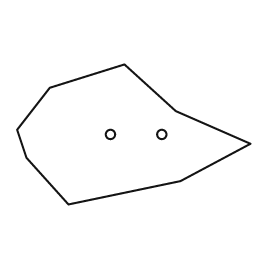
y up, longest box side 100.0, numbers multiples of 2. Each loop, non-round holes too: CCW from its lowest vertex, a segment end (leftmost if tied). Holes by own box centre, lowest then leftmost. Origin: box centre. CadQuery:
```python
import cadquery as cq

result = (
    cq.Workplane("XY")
    .moveTo(-28.0, -30.0)
    .lineTo(20.0, -20.0)
    .lineTo(50.0, -4.0)
    .lineTo(18.0, 10.0)
    .lineTo(-4.0, 30.0)
    .lineTo(-36.0, 20.0)
    .lineTo(-50.0, 2.0)
    .lineTo(-46.0, -10.0)
    .close()
    .moveTo(-10.0, 0.0)
    .circle(2.0)
    .moveTo(12.0, 0.0)
    .circle(2.0)
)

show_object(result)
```